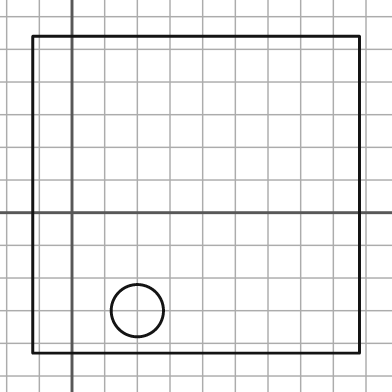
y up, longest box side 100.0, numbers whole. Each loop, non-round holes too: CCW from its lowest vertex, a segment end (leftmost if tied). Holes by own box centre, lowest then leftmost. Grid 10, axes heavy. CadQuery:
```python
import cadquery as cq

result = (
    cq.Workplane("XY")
    .moveTo(-12.0, -43.0)
    .lineTo(88.0, -43.0)
    .lineTo(88.0, 54.0)
    .lineTo(-12.0, 54.0)
    .close()
    .moveTo(20.0, -30.0)
    .circle(8.0)
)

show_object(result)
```